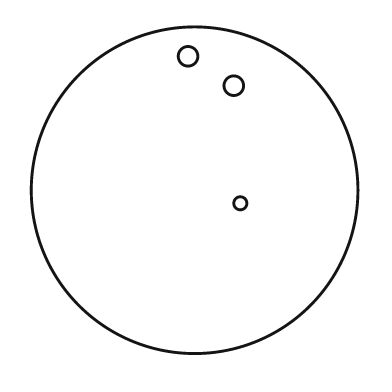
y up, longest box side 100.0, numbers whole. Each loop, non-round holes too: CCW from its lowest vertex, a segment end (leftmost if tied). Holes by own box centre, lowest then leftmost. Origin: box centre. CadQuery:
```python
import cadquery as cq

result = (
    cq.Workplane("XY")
    .moveTo(0.0, 0.0)
    .circle(50.0)
    .moveTo(14.0, -4.0)
    .circle(2.0)
    .moveTo(12.0, 32.0)
    .circle(3.0)
    .moveTo(-2.0, 41.0)
    .circle(3.0)
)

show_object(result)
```